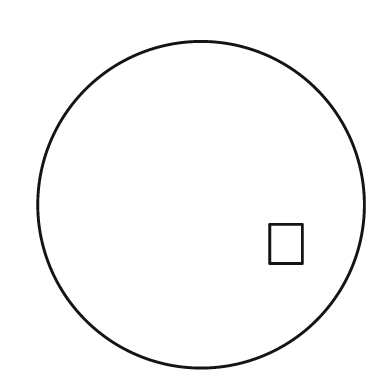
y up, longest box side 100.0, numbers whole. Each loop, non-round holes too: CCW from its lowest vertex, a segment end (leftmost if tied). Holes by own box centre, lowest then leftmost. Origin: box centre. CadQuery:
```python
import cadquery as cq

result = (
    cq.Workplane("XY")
    .moveTo(0.0, 0.0)
    .circle(50.0)
    .moveTo(21.0, -18.0)
    .lineTo(31.0, -18.0)
    .lineTo(31.0, -6.0)
    .lineTo(21.0, -6.0)
    .close()
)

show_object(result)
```